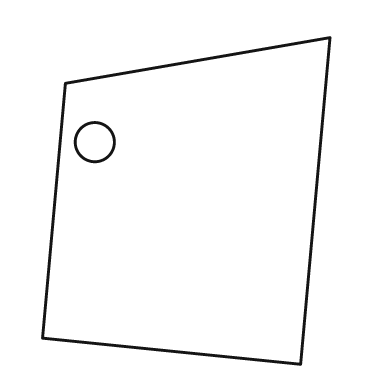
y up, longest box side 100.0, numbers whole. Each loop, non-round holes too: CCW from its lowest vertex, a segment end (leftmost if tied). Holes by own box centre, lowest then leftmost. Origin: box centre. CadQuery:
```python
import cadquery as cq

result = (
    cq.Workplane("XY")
    .moveTo(35.0, -50.0)
    .lineTo(44.0, 50.0)
    .lineTo(-37.0, 36.0)
    .lineTo(-44.0, -42.0)
    .close()
    .moveTo(-28.0, 18.0)
    .circle(6.0)
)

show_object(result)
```